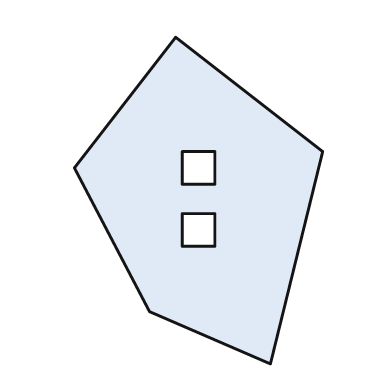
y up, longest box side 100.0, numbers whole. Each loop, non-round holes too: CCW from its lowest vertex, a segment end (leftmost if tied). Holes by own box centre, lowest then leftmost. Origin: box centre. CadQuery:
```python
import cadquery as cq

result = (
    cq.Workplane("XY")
    .moveTo(22.0, -50.0)
    .lineTo(38.0, 15.0)
    .lineTo(-7.0, 50.0)
    .lineTo(-38.0, 10.0)
    .lineTo(-15.0, -34.0)
    .close()
    .moveTo(-5.0, -14.0)
    .lineTo(5.0, -14.0)
    .lineTo(5.0, -4.0)
    .lineTo(-5.0, -4.0)
    .close()
    .moveTo(-5.0, 5.0)
    .lineTo(5.0, 5.0)
    .lineTo(5.0, 15.0)
    .lineTo(-5.0, 15.0)
    .close()
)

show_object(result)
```